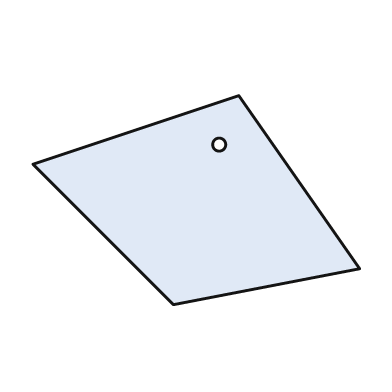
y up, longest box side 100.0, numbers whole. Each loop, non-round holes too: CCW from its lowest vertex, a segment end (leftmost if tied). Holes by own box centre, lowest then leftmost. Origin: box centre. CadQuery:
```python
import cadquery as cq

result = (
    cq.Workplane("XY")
    .moveTo(-7.0, -32.0)
    .lineTo(50.0, -21.0)
    .lineTo(13.0, 32.0)
    .lineTo(-50.0, 11.0)
    .close()
    .moveTo(7.0, 17.0)
    .circle(2.0)
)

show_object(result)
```